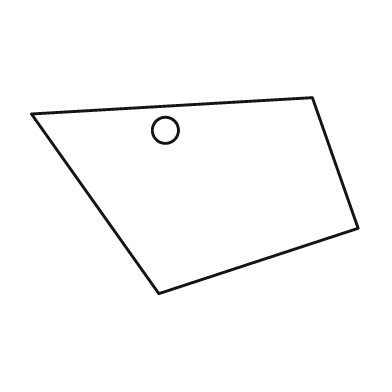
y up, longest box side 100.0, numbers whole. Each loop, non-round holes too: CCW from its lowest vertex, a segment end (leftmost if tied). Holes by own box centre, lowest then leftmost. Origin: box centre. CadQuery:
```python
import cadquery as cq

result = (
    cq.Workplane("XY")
    .moveTo(-11.0, -30.0)
    .lineTo(50.0, -10.0)
    .lineTo(36.0, 30.0)
    .lineTo(-50.0, 25.0)
    .close()
    .moveTo(-9.0, 20.0)
    .circle(4.0)
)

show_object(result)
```